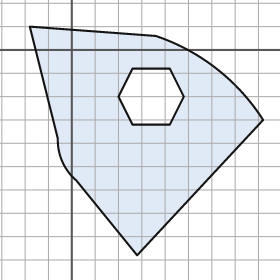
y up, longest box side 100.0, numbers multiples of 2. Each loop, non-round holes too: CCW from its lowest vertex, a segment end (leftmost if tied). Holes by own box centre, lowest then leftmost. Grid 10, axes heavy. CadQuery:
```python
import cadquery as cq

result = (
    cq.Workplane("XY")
    .moveTo(28.0, -88.0)
    .lineTo(82.0, -30.0)
    .threePointArc((62.0, -8.0), (36.0, 6.0))
    .lineTo(-18.0, 10.0)
    .lineTo(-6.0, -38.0)
    .threePointArc((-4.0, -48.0), (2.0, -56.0))
    .close()
    .moveTo(26.0, -32.0)
    .lineTo(42.0, -32.0)
    .lineTo(48.0, -20.0)
    .lineTo(42.0, -8.0)
    .lineTo(26.0, -8.0)
    .lineTo(20.0, -20.0)
    .close()
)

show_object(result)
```